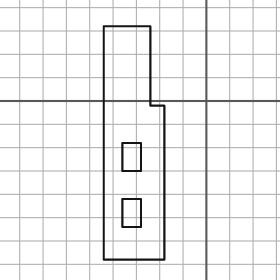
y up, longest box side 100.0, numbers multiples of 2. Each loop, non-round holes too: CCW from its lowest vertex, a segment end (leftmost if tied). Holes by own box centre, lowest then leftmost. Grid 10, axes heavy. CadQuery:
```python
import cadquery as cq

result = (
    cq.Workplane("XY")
    .moveTo(-44.0, -68.0)
    .lineTo(-18.0, -68.0)
    .lineTo(-18.0, -2.0)
    .lineTo(-24.0, -2.0)
    .lineTo(-24.0, 32.0)
    .lineTo(-44.0, 32.0)
    .close()
    .moveTo(-36.0, -54.0)
    .lineTo(-28.0, -54.0)
    .lineTo(-28.0, -42.0)
    .lineTo(-36.0, -42.0)
    .close()
    .moveTo(-36.0, -30.0)
    .lineTo(-28.0, -30.0)
    .lineTo(-28.0, -18.0)
    .lineTo(-36.0, -18.0)
    .close()
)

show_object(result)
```